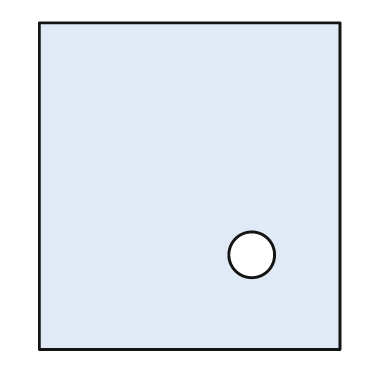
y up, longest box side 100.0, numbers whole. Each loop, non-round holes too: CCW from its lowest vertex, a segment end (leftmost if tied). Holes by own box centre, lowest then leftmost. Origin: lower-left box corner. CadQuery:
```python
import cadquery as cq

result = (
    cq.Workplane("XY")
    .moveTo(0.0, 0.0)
    .lineTo(92.0, 0.0)
    .lineTo(92.0, 100.0)
    .lineTo(0.0, 100.0)
    .close()
    .moveTo(65.0, 29.0)
    .circle(7.0)
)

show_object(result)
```